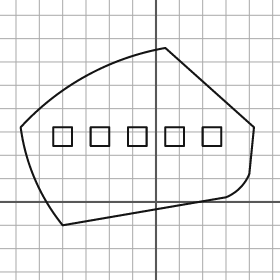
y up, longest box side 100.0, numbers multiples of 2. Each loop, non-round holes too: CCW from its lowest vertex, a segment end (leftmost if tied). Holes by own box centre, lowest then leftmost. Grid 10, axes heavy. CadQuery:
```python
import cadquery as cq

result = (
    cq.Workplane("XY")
    .moveTo(-40.0, -10.0)
    .lineTo(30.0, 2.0)
    .threePointArc((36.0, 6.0), (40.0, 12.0))
    .lineTo(42.0, 32.0)
    .lineTo(4.0, 66.0)
    .threePointArc((-30.0, 54.0), (-58.0, 32.0))
    .threePointArc((-52.0, 10.0), (-40.0, -10.0))
    .close()
    .moveTo(-44.0, 24.0)
    .lineTo(-36.0, 24.0)
    .lineTo(-36.0, 32.0)
    .lineTo(-44.0, 32.0)
    .close()
    .moveTo(-28.0, 24.0)
    .lineTo(-20.0, 24.0)
    .lineTo(-20.0, 32.0)
    .lineTo(-28.0, 32.0)
    .close()
    .moveTo(-12.0, 24.0)
    .lineTo(-4.0, 24.0)
    .lineTo(-4.0, 32.0)
    .lineTo(-12.0, 32.0)
    .close()
    .moveTo(4.0, 24.0)
    .lineTo(12.0, 24.0)
    .lineTo(12.0, 32.0)
    .lineTo(4.0, 32.0)
    .close()
    .moveTo(20.0, 24.0)
    .lineTo(28.0, 24.0)
    .lineTo(28.0, 32.0)
    .lineTo(20.0, 32.0)
    .close()
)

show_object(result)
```